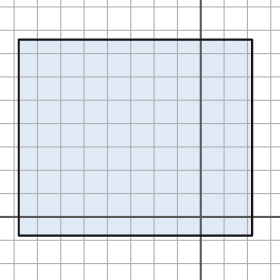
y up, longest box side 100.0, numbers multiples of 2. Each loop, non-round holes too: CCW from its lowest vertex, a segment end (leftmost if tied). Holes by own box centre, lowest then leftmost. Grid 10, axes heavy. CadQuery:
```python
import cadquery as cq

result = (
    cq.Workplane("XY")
    .moveTo(-78.0, -8.0)
    .lineTo(22.0, -8.0)
    .lineTo(22.0, 76.0)
    .lineTo(-78.0, 76.0)
    .close()
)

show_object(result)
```